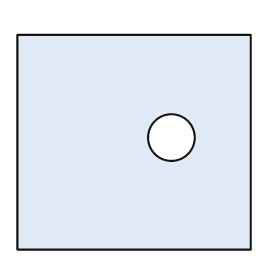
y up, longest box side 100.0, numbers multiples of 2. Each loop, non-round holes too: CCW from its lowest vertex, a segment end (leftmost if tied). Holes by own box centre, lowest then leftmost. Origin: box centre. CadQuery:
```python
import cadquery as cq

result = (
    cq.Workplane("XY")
    .moveTo(-50.0, -46.0)
    .lineTo(50.0, -46.0)
    .lineTo(50.0, 46.0)
    .lineTo(-50.0, 46.0)
    .close()
    .moveTo(16.0, 2.0)
    .circle(10.0)
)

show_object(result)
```